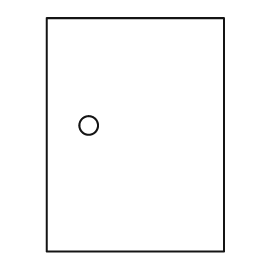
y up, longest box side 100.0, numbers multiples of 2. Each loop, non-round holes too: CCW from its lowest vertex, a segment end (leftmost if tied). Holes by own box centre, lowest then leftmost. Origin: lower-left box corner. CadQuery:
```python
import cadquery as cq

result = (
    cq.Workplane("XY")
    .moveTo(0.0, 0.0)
    .lineTo(76.0, 0.0)
    .lineTo(76.0, 100.0)
    .lineTo(0.0, 100.0)
    .close()
    .moveTo(18.0, 54.0)
    .circle(4.0)
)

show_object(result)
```